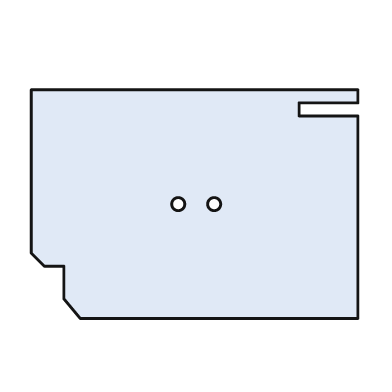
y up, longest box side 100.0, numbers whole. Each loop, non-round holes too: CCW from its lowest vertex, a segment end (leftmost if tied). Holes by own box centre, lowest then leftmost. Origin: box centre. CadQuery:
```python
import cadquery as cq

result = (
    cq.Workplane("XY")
    .moveTo(-35.0, -35.0)
    .lineTo(50.0, -35.0)
    .lineTo(50.0, 27.0)
    .lineTo(32.0, 27.0)
    .lineTo(32.0, 31.0)
    .lineTo(50.0, 31.0)
    .lineTo(50.0, 35.0)
    .lineTo(-50.0, 35.0)
    .lineTo(-50.0, -15.0)
    .lineTo(-46.0, -19.0)
    .lineTo(-40.0, -19.0)
    .lineTo(-40.0, -29.0)
    .close()
    .moveTo(-5.0, 0.0)
    .circle(2.0)
    .moveTo(6.0, 0.0)
    .circle(2.0)
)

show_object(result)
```